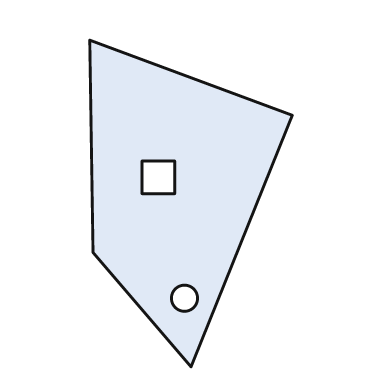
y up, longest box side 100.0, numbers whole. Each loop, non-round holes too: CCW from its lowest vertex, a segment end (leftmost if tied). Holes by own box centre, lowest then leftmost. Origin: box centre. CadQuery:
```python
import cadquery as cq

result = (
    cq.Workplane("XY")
    .moveTo(0.0, -50.0)
    .lineTo(31.0, 27.0)
    .lineTo(-31.0, 50.0)
    .lineTo(-30.0, -15.0)
    .close()
    .moveTo(-2.0, -29.0)
    .circle(4.0)
    .moveTo(-15.0, 3.0)
    .lineTo(-5.0, 3.0)
    .lineTo(-5.0, 13.0)
    .lineTo(-15.0, 13.0)
    .close()
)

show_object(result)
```